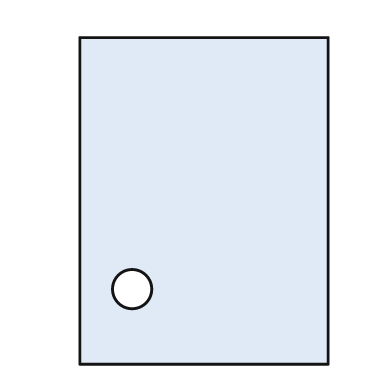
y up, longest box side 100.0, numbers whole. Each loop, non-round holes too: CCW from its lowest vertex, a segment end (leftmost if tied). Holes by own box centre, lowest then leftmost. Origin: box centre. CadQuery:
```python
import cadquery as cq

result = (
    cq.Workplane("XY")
    .moveTo(-38.0, -50.0)
    .lineTo(38.0, -50.0)
    .lineTo(38.0, 50.0)
    .lineTo(-38.0, 50.0)
    .close()
    .moveTo(-22.0, -27.0)
    .circle(6.0)
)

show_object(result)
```